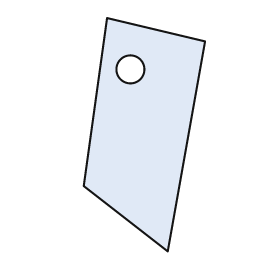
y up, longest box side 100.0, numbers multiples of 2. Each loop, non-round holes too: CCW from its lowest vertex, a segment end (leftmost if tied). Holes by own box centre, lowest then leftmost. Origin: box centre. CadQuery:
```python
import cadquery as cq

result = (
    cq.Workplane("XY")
    .moveTo(10.0, -50.0)
    .lineTo(26.0, 40.0)
    .lineTo(-16.0, 50.0)
    .lineTo(-26.0, -22.0)
    .close()
    .moveTo(-6.0, 28.0)
    .circle(6.0)
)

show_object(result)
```